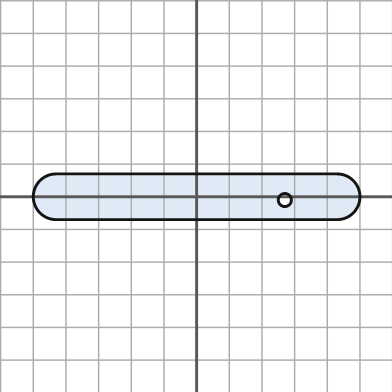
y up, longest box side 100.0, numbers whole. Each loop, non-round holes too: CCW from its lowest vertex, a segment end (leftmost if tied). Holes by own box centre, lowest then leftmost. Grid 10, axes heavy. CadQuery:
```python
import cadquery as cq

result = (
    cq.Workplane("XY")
    .moveTo(-43.0, -7.0)
    .lineTo(43.0, -7.0)
    .threePointArc((50.0, 0.0), (43.0, 7.0))
    .lineTo(-43.0, 7.0)
    .threePointArc((-50.0, 0.0), (-43.0, -7.0))
    .close()
    .moveTo(27.0, -1.0)
    .circle(2.0)
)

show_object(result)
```